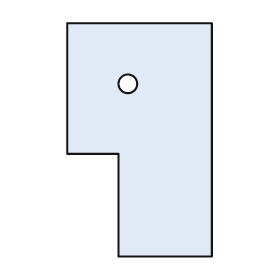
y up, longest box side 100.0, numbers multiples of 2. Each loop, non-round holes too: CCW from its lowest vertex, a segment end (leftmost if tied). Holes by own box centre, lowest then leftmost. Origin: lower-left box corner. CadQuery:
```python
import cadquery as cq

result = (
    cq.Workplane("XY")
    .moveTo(22.0, 0.0)
    .lineTo(62.0, 0.0)
    .lineTo(62.0, 100.0)
    .lineTo(0.0, 100.0)
    .lineTo(0.0, 44.0)
    .lineTo(22.0, 44.0)
    .close()
    .moveTo(26.0, 74.0)
    .circle(4.0)
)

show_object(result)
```